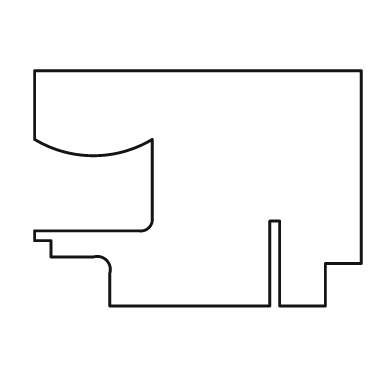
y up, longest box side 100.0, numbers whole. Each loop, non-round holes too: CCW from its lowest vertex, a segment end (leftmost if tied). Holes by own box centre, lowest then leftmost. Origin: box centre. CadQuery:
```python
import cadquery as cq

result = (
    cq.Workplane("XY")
    .moveTo(-27.0, -36.0)
    .lineTo(22.0, -36.0)
    .lineTo(22.0, -10.0)
    .lineTo(25.0, -10.0)
    .lineTo(25.0, -36.0)
    .lineTo(39.0, -36.0)
    .lineTo(39.0, -23.0)
    .lineTo(50.0, -23.0)
    .lineTo(50.0, 36.0)
    .lineTo(-50.0, 36.0)
    .lineTo(-50.0, 15.0)
    .threePointArc((-32.0, 10.0), (-14.0, 15.0))
    .lineTo(-14.0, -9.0)
    .threePointArc((-15.0, -12.0), (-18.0, -13.0))
    .lineTo(-50.0, -13.0)
    .lineTo(-50.0, -16.0)
    .lineTo(-45.0, -16.0)
    .lineTo(-45.0, -21.0)
    .lineTo(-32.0, -21.0)
    .threePointArc((-28.0, -22.0), (-27.0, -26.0))
    .close()
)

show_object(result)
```